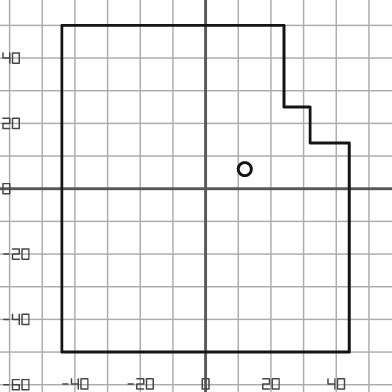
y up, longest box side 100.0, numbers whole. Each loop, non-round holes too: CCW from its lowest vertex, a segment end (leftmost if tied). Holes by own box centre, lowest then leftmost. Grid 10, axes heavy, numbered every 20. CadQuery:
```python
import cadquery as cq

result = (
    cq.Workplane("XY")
    .moveTo(-44.0, -50.0)
    .lineTo(44.0, -50.0)
    .lineTo(44.0, 14.0)
    .lineTo(32.0, 14.0)
    .lineTo(32.0, 25.0)
    .lineTo(24.0, 25.0)
    .lineTo(24.0, 50.0)
    .lineTo(-44.0, 50.0)
    .close()
    .moveTo(12.0, 6.0)
    .circle(2.0)
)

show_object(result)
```